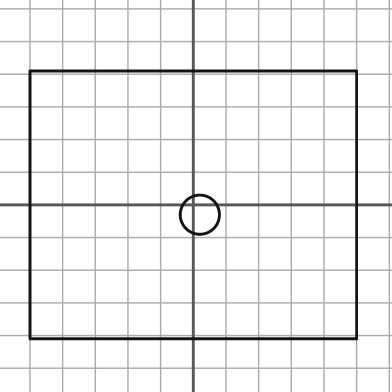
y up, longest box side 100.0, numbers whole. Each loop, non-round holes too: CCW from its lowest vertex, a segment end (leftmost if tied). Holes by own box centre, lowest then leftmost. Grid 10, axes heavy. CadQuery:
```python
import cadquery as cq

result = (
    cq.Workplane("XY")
    .moveTo(-50.0, -41.0)
    .lineTo(50.0, -41.0)
    .lineTo(50.0, 41.0)
    .lineTo(-50.0, 41.0)
    .close()
    .moveTo(2.0, -3.0)
    .circle(6.0)
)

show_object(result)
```